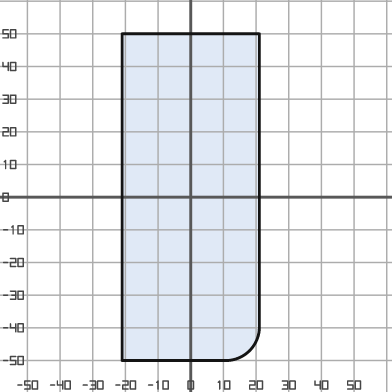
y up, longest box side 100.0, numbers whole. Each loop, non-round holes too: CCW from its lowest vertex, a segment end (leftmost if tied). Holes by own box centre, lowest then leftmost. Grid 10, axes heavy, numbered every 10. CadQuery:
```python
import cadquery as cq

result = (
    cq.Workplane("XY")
    .moveTo(-21.0, -50.0)
    .lineTo(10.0, -50.0)
    .threePointArc((18.0, -47.0), (21.0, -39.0))
    .lineTo(21.0, 50.0)
    .lineTo(-21.0, 50.0)
    .close()
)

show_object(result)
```